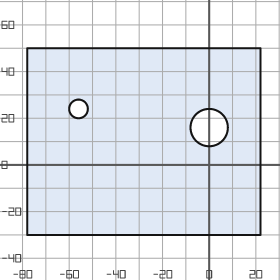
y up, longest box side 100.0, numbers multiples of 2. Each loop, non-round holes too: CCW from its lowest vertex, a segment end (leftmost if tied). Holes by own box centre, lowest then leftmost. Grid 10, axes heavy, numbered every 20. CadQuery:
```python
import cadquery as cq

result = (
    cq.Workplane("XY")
    .moveTo(-78.0, -30.0)
    .lineTo(22.0, -30.0)
    .lineTo(22.0, 50.0)
    .lineTo(-78.0, 50.0)
    .close()
    .moveTo(0.0, 16.0)
    .circle(8.0)
    .moveTo(-56.0, 24.0)
    .circle(4.0)
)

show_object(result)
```